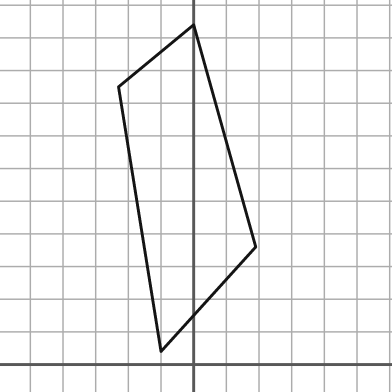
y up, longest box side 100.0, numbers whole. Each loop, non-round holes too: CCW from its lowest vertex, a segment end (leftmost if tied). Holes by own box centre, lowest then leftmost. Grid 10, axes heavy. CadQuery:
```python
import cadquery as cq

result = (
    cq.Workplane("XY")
    .moveTo(-10.0, 4.0)
    .lineTo(19.0, 36.0)
    .lineTo(0.0, 104.0)
    .lineTo(-23.0, 85.0)
    .close()
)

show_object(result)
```